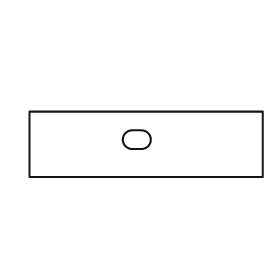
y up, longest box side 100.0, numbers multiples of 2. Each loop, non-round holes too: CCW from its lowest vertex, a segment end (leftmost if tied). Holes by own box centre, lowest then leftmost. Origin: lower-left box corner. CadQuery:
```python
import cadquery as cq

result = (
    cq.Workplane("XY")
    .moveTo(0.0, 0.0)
    .lineTo(100.0, 0.0)
    .lineTo(100.0, 28.0)
    .lineTo(0.0, 28.0)
    .close()
    .moveTo(44.0, 12.0)
    .lineTo(48.0, 12.0)
    .threePointArc((52.0, 16.0), (48.0, 20.0))
    .lineTo(44.0, 20.0)
    .threePointArc((40.0, 16.0), (44.0, 12.0))
    .close()
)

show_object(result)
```